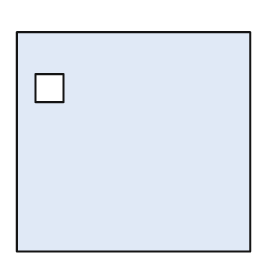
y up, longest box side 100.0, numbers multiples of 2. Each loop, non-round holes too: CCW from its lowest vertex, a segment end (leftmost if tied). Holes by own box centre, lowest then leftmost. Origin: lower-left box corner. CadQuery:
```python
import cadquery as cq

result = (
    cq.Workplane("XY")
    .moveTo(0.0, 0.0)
    .lineTo(100.0, 0.0)
    .lineTo(100.0, 94.0)
    .lineTo(0.0, 94.0)
    .close()
    .moveTo(8.0, 64.0)
    .lineTo(20.0, 64.0)
    .lineTo(20.0, 76.0)
    .lineTo(8.0, 76.0)
    .close()
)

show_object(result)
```